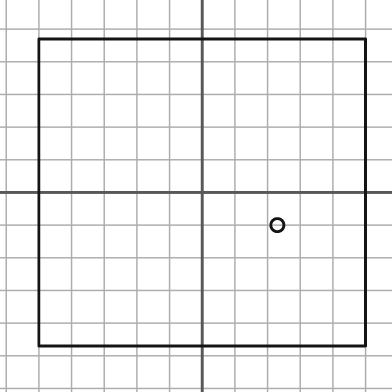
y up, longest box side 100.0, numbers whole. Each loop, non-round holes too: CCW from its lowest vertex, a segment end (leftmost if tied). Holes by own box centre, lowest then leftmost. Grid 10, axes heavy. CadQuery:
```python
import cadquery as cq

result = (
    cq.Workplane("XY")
    .moveTo(-50.0, -47.0)
    .lineTo(50.0, -47.0)
    .lineTo(50.0, 47.0)
    .lineTo(-50.0, 47.0)
    .close()
    .moveTo(23.0, -10.0)
    .circle(2.0)
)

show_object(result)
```